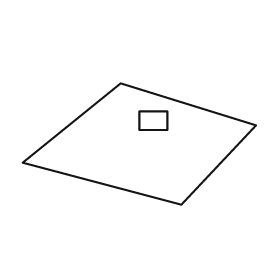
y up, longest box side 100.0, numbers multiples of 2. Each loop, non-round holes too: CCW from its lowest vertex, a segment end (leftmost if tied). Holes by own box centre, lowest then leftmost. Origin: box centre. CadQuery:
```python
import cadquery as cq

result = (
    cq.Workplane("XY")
    .moveTo(18.0, -26.0)
    .lineTo(50.0, 8.0)
    .lineTo(-8.0, 26.0)
    .lineTo(-50.0, -8.0)
    .close()
    .moveTo(0.0, 6.0)
    .lineTo(12.0, 6.0)
    .lineTo(12.0, 14.0)
    .lineTo(0.0, 14.0)
    .close()
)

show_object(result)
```